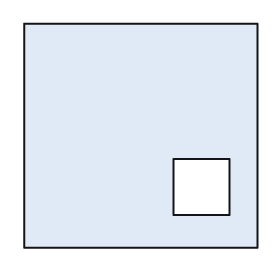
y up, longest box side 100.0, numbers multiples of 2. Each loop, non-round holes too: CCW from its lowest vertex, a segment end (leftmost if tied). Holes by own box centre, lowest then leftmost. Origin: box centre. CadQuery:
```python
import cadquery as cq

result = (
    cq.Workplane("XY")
    .moveTo(-50.0, -48.0)
    .lineTo(50.0, -48.0)
    .lineTo(50.0, 48.0)
    .lineTo(-50.0, 48.0)
    .close()
    .moveTo(14.0, -34.0)
    .lineTo(38.0, -34.0)
    .lineTo(38.0, -10.0)
    .lineTo(14.0, -10.0)
    .close()
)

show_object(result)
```